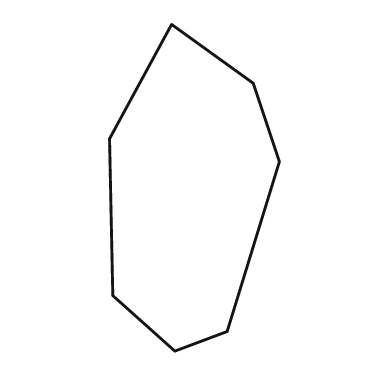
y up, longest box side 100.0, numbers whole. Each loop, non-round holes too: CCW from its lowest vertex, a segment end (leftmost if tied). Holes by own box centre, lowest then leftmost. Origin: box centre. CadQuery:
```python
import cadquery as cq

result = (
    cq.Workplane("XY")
    .moveTo(-6.0, -50.0)
    .lineTo(10.0, -44.0)
    .lineTo(26.0, 8.0)
    .lineTo(18.0, 32.0)
    .lineTo(-7.0, 50.0)
    .lineTo(-26.0, 15.0)
    .lineTo(-25.0, -33.0)
    .close()
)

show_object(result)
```